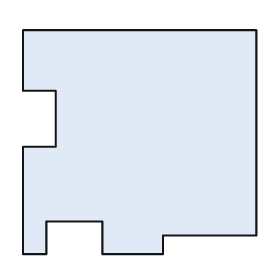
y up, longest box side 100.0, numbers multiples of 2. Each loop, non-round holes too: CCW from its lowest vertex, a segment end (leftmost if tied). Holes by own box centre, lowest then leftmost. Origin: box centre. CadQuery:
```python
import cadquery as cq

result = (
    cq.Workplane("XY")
    .moveTo(-50.0, -48.0)
    .lineTo(-40.0, -48.0)
    .lineTo(-40.0, -34.0)
    .lineTo(-16.0, -34.0)
    .lineTo(-16.0, -48.0)
    .lineTo(10.0, -48.0)
    .lineTo(10.0, -40.0)
    .lineTo(50.0, -40.0)
    .lineTo(50.0, 48.0)
    .lineTo(-50.0, 48.0)
    .lineTo(-50.0, 22.0)
    .lineTo(-36.0, 22.0)
    .lineTo(-36.0, -2.0)
    .lineTo(-50.0, -2.0)
    .close()
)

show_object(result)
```